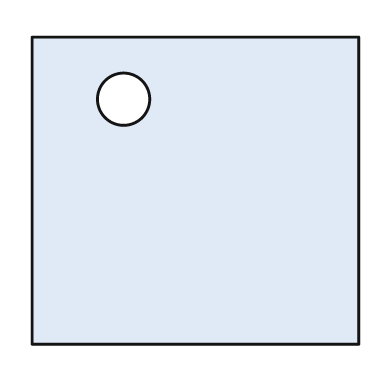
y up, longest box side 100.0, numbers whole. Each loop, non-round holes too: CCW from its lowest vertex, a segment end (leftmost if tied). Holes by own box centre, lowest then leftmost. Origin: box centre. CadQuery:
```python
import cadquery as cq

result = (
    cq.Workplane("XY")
    .moveTo(-50.0, -47.0)
    .lineTo(50.0, -47.0)
    .lineTo(50.0, 47.0)
    .lineTo(-50.0, 47.0)
    .close()
    .moveTo(-22.0, 28.0)
    .circle(8.0)
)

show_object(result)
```